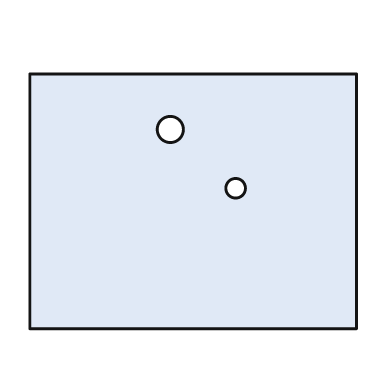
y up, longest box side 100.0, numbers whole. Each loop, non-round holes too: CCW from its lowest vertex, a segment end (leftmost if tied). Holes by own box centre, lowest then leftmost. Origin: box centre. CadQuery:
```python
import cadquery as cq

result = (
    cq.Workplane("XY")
    .moveTo(-50.0, -39.0)
    .lineTo(50.0, -39.0)
    .lineTo(50.0, 39.0)
    .lineTo(-50.0, 39.0)
    .close()
    .moveTo(13.0, 4.0)
    .circle(3.0)
    .moveTo(-7.0, 22.0)
    .circle(4.0)
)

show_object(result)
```